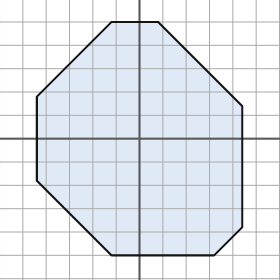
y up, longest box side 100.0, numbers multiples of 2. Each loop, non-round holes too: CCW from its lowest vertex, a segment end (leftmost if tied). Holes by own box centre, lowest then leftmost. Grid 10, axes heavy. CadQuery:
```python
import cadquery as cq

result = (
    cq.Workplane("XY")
    .moveTo(-12.0, -50.0)
    .lineTo(32.0, -50.0)
    .lineTo(44.0, -38.0)
    .lineTo(44.0, 14.0)
    .lineTo(8.0, 50.0)
    .lineTo(-12.0, 50.0)
    .lineTo(-44.0, 18.0)
    .lineTo(-44.0, -18.0)
    .close()
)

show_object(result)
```